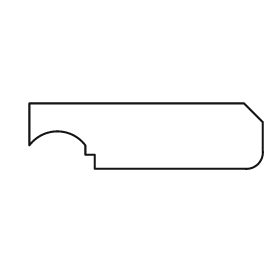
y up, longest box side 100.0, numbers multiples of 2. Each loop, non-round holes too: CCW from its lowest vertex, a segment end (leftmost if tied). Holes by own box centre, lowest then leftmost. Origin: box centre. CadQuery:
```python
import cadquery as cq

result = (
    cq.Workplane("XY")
    .moveTo(-22.0, -14.0)
    .lineTo(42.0, -14.0)
    .threePointArc((48.0, -12.0), (50.0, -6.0))
    .lineTo(50.0, 6.0)
    .lineTo(42.0, 14.0)
    .lineTo(-50.0, 14.0)
    .lineTo(-50.0, -4.0)
    .threePointArc((-38.0, 2.0), (-26.0, -4.0))
    .lineTo(-26.0, -8.0)
    .lineTo(-22.0, -8.0)
    .close()
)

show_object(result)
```